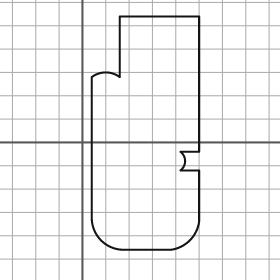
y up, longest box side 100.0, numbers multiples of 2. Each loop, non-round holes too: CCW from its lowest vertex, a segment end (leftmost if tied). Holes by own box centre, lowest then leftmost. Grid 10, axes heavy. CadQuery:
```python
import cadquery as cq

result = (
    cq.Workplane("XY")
    .moveTo(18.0, -46.0)
    .lineTo(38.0, -46.0)
    .threePointArc((46.0, -42.0), (50.0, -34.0))
    .lineTo(50.0, -12.0)
    .lineTo(42.0, -12.0)
    .threePointArc((44.0, -8.0), (42.0, -4.0))
    .lineTo(50.0, -4.0)
    .lineTo(50.0, 54.0)
    .lineTo(16.0, 54.0)
    .lineTo(16.0, 28.0)
    .threePointArc((10.0, 30.0), (4.0, 28.0))
    .lineTo(4.0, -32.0)
    .threePointArc((8.0, -42.0), (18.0, -46.0))
    .close()
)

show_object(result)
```